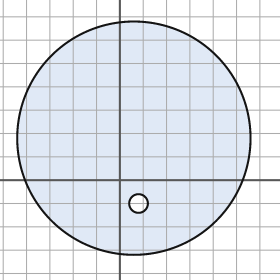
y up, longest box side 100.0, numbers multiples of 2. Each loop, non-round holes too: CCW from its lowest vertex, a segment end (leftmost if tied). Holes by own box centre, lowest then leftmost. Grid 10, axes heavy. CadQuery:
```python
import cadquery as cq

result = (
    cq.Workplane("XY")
    .moveTo(6.0, 18.0)
    .circle(50.0)
    .moveTo(8.0, -10.0)
    .circle(4.0)
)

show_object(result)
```